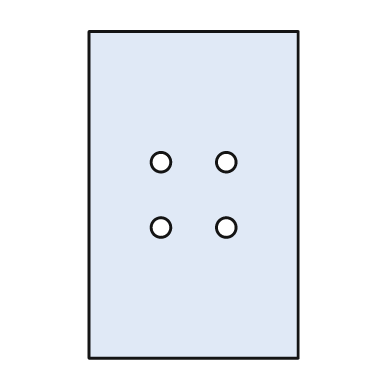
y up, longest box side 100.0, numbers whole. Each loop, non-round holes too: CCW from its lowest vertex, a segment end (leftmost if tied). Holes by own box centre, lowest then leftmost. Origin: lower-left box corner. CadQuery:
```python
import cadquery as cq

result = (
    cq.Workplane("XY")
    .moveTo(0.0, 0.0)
    .lineTo(64.0, 0.0)
    .lineTo(64.0, 100.0)
    .lineTo(0.0, 100.0)
    .close()
    .moveTo(22.0, 40.0)
    .circle(3.0)
    .moveTo(42.0, 40.0)
    .circle(3.0)
    .moveTo(22.0, 60.0)
    .circle(3.0)
    .moveTo(42.0, 60.0)
    .circle(3.0)
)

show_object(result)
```